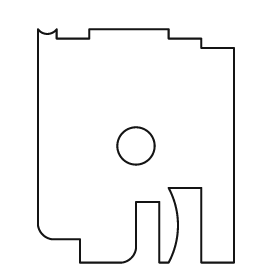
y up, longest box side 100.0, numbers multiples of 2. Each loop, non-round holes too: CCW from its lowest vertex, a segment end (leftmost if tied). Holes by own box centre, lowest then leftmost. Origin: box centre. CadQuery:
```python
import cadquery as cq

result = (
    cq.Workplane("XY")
    .moveTo(-24.0, -50.0)
    .lineTo(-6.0, -50.0)
    .threePointArc((-2.0, -48.0), (0.0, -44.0))
    .lineTo(0.0, -24.0)
    .lineTo(10.0, -24.0)
    .lineTo(10.0, -50.0)
    .lineTo(14.0, -50.0)
    .threePointArc((18.0, -34.0), (14.0, -18.0))
    .lineTo(28.0, -18.0)
    .lineTo(28.0, -50.0)
    .lineTo(42.0, -50.0)
    .lineTo(42.0, 42.0)
    .lineTo(28.0, 42.0)
    .lineTo(28.0, 46.0)
    .lineTo(14.0, 46.0)
    .lineTo(14.0, 50.0)
    .lineTo(-20.0, 50.0)
    .lineTo(-20.0, 46.0)
    .lineTo(-34.0, 46.0)
    .lineTo(-34.0, 50.0)
    .threePointArc((-38.0, 48.0), (-42.0, 50.0))
    .lineTo(-42.0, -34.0)
    .threePointArc((-40.0, -38.0), (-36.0, -40.0))
    .lineTo(-24.0, -40.0)
    .close()
    .moveTo(0.0, 0.0)
    .circle(8.0)
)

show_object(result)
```